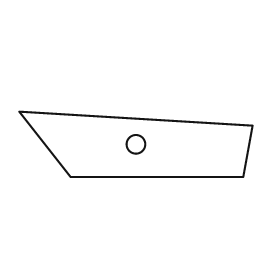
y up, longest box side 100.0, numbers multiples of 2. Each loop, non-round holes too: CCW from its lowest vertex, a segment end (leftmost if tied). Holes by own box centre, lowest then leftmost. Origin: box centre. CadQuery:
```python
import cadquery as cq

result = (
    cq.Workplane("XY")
    .moveTo(-28.0, -14.0)
    .lineTo(46.0, -14.0)
    .lineTo(50.0, 8.0)
    .lineTo(-50.0, 14.0)
    .close()
    .moveTo(0.0, 0.0)
    .circle(4.0)
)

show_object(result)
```